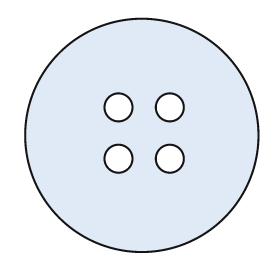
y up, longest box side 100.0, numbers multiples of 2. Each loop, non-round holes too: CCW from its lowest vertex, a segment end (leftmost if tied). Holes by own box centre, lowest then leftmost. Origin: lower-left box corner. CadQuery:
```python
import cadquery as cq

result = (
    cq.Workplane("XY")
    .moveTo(50.0, 50.0)
    .circle(50.0)
    .moveTo(40.0, 40.0)
    .circle(6.0)
    .moveTo(62.0, 40.0)
    .circle(6.0)
    .moveTo(40.0, 62.0)
    .circle(6.0)
    .moveTo(62.0, 62.0)
    .circle(6.0)
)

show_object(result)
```